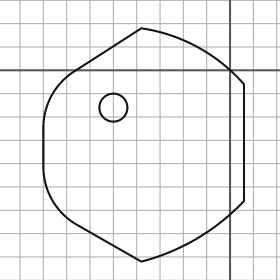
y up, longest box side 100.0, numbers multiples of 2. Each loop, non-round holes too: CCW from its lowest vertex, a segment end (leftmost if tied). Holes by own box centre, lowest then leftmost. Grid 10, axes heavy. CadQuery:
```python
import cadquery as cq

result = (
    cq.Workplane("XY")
    .moveTo(-38.0, -82.0)
    .threePointArc((-14.0, -72.0), (6.0, -56.0))
    .lineTo(6.0, -6.0)
    .threePointArc((-14.0, 10.0), (-38.0, 18.0))
    .lineTo(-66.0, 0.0)
    .threePointArc((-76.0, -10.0), (-80.0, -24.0))
    .lineTo(-80.0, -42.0)
    .threePointArc((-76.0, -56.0), (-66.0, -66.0))
    .close()
    .moveTo(-50.0, -16.0)
    .circle(6.0)
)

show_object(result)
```